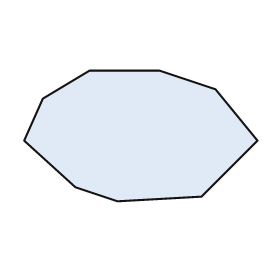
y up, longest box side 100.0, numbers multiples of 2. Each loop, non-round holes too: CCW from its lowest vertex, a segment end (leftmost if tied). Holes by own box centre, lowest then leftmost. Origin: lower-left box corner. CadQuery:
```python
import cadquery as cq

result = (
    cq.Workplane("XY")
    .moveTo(40.0, 0.0)
    .lineTo(76.0, 2.0)
    .lineTo(100.0, 26.0)
    .lineTo(82.0, 48.0)
    .lineTo(58.0, 56.0)
    .lineTo(28.0, 56.0)
    .lineTo(8.0, 44.0)
    .lineTo(0.0, 26.0)
    .lineTo(22.0, 6.0)
    .close()
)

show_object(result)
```